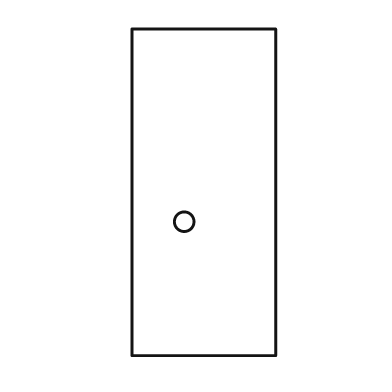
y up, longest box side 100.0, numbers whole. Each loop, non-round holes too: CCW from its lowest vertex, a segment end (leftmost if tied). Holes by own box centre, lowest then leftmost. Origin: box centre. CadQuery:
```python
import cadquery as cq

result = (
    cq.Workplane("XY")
    .moveTo(-22.0, -50.0)
    .lineTo(22.0, -50.0)
    .lineTo(22.0, 50.0)
    .lineTo(-22.0, 50.0)
    .close()
    .moveTo(-6.0, -9.0)
    .circle(3.0)
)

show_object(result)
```